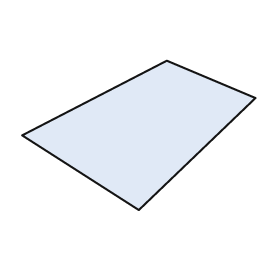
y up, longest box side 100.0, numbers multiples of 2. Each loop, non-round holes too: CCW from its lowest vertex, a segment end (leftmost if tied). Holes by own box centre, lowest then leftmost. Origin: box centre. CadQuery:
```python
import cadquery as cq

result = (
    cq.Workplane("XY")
    .moveTo(0.0, -32.0)
    .lineTo(50.0, 16.0)
    .lineTo(12.0, 32.0)
    .lineTo(-50.0, 0.0)
    .close()
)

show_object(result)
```